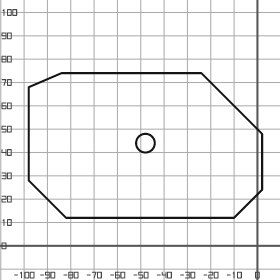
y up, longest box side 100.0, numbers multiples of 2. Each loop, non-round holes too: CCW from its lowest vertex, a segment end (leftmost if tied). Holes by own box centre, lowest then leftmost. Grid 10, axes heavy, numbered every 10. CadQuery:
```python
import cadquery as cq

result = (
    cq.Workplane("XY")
    .moveTo(-82.0, 12.0)
    .lineTo(-10.0, 12.0)
    .lineTo(2.0, 24.0)
    .lineTo(2.0, 48.0)
    .lineTo(-24.0, 74.0)
    .lineTo(-84.0, 74.0)
    .lineTo(-98.0, 68.0)
    .lineTo(-98.0, 28.0)
    .close()
    .moveTo(-48.0, 44.0)
    .circle(4.0)
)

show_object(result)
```